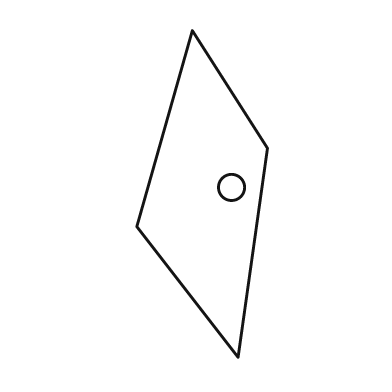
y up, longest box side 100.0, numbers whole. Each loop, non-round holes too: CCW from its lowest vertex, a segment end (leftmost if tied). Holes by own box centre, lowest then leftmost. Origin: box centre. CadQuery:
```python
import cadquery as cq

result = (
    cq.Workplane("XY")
    .moveTo(11.0, -50.0)
    .lineTo(20.0, 14.0)
    .lineTo(-3.0, 50.0)
    .lineTo(-20.0, -10.0)
    .close()
    .moveTo(9.0, 2.0)
    .circle(4.0)
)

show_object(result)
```